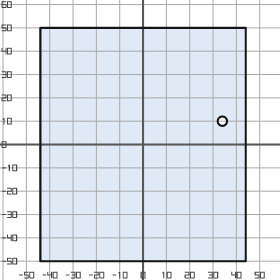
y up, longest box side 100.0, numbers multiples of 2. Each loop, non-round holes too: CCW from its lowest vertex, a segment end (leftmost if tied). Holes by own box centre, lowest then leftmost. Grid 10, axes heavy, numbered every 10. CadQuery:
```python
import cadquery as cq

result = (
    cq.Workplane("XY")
    .moveTo(-44.0, -50.0)
    .lineTo(44.0, -50.0)
    .lineTo(44.0, 50.0)
    .lineTo(-44.0, 50.0)
    .close()
    .moveTo(34.0, 10.0)
    .circle(2.0)
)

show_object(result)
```